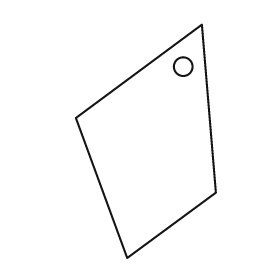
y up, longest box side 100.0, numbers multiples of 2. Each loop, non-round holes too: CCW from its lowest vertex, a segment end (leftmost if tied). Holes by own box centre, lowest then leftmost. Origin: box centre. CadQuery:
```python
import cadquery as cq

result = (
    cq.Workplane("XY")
    .moveTo(-8.0, -50.0)
    .lineTo(30.0, -22.0)
    .lineTo(24.0, 50.0)
    .lineTo(-30.0, 10.0)
    .close()
    .moveTo(16.0, 32.0)
    .circle(4.0)
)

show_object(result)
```